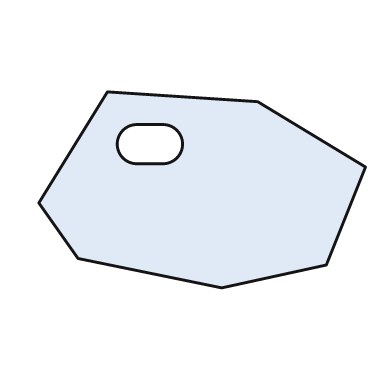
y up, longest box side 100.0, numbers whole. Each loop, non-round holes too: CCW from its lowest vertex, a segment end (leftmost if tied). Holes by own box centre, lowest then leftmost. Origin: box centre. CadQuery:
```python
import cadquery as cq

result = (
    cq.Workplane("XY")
    .moveTo(6.0, -30.0)
    .lineTo(38.0, -23.0)
    .lineTo(50.0, 7.0)
    .lineTo(17.0, 27.0)
    .lineTo(-29.0, 30.0)
    .lineTo(-50.0, -4.0)
    .lineTo(-38.0, -21.0)
    .close()
    .moveTo(-20.0, 8.0)
    .lineTo(-12.0, 8.0)
    .threePointArc((-6.0, 14.0), (-12.0, 20.0))
    .lineTo(-20.0, 20.0)
    .threePointArc((-26.0, 14.0), (-20.0, 8.0))
    .close()
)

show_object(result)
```